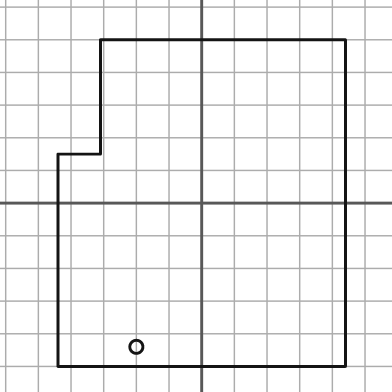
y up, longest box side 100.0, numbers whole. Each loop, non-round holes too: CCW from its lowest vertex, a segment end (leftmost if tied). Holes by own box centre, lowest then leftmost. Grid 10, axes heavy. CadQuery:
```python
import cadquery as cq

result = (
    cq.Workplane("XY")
    .moveTo(-44.0, -50.0)
    .lineTo(44.0, -50.0)
    .lineTo(44.0, 50.0)
    .lineTo(-31.0, 50.0)
    .lineTo(-31.0, 15.0)
    .lineTo(-44.0, 15.0)
    .close()
    .moveTo(-20.0, -44.0)
    .circle(2.0)
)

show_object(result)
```